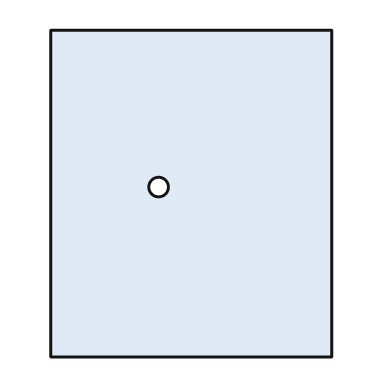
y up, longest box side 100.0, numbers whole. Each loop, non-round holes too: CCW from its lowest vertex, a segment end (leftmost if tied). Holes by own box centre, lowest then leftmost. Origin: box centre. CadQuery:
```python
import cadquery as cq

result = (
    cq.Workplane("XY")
    .moveTo(-43.0, -50.0)
    .lineTo(43.0, -50.0)
    .lineTo(43.0, 50.0)
    .lineTo(-43.0, 50.0)
    .close()
    .moveTo(-10.0, 2.0)
    .circle(3.0)
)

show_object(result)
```